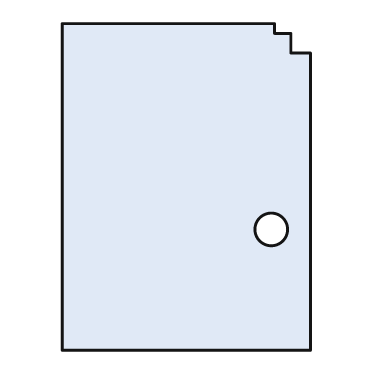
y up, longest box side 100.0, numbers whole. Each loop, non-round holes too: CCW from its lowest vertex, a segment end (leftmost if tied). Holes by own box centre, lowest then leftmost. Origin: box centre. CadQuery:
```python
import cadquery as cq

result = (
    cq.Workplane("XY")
    .moveTo(-38.0, -50.0)
    .lineTo(38.0, -50.0)
    .lineTo(38.0, 41.0)
    .lineTo(32.0, 41.0)
    .lineTo(32.0, 47.0)
    .lineTo(27.0, 47.0)
    .lineTo(27.0, 50.0)
    .lineTo(-38.0, 50.0)
    .close()
    .moveTo(26.0, -13.0)
    .circle(5.0)
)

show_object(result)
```